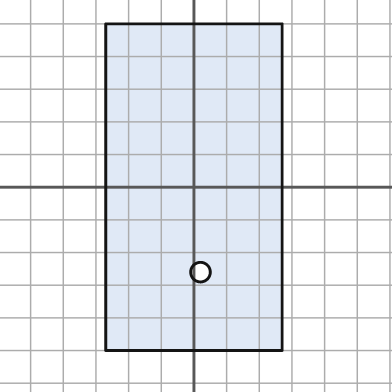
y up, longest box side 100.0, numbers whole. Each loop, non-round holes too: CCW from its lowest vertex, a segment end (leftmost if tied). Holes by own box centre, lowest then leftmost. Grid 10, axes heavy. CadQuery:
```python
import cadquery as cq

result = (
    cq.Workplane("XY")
    .moveTo(-27.0, -50.0)
    .lineTo(27.0, -50.0)
    .lineTo(27.0, 50.0)
    .lineTo(-27.0, 50.0)
    .close()
    .moveTo(2.0, -26.0)
    .circle(3.0)
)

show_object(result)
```